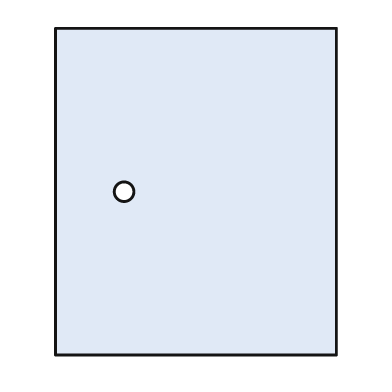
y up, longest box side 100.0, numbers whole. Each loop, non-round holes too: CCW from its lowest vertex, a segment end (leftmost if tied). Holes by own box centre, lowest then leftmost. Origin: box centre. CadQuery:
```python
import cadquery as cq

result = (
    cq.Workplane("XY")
    .moveTo(-43.0, -50.0)
    .lineTo(43.0, -50.0)
    .lineTo(43.0, 50.0)
    .lineTo(-43.0, 50.0)
    .close()
    .moveTo(-22.0, 0.0)
    .circle(3.0)
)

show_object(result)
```